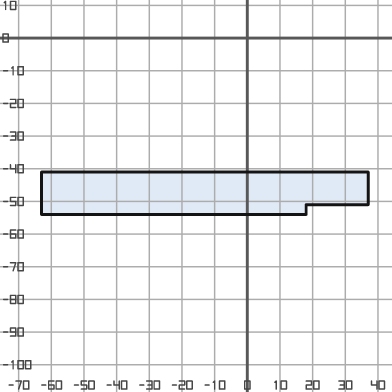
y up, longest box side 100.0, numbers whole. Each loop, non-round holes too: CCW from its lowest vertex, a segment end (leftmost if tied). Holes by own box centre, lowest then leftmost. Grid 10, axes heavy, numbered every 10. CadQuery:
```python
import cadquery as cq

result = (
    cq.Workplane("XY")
    .moveTo(-63.0, -54.0)
    .lineTo(18.0, -54.0)
    .lineTo(18.0, -51.0)
    .lineTo(37.0, -51.0)
    .lineTo(37.0, -41.0)
    .lineTo(-63.0, -41.0)
    .close()
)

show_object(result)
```